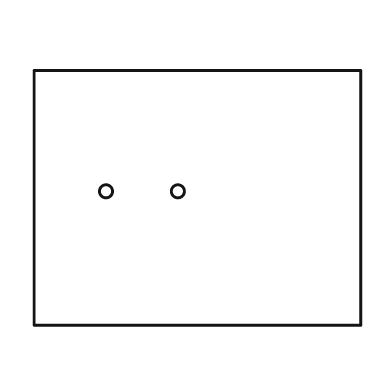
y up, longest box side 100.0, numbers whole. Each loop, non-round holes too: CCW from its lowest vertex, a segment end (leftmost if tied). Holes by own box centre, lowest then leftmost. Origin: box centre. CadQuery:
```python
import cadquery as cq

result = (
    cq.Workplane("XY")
    .moveTo(-50.0, -39.0)
    .lineTo(50.0, -39.0)
    .lineTo(50.0, 39.0)
    .lineTo(-50.0, 39.0)
    .close()
    .moveTo(-28.0, 2.0)
    .circle(2.0)
    .moveTo(-6.0, 2.0)
    .circle(2.0)
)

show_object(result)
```